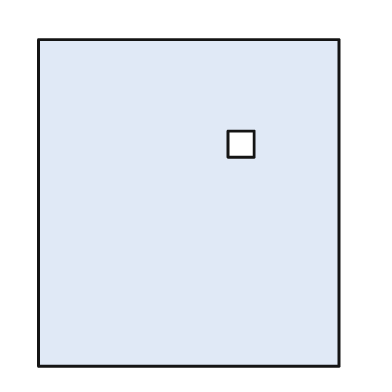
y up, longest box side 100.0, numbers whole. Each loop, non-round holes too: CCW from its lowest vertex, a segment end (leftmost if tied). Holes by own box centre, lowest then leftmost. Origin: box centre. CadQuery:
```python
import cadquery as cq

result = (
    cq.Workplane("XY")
    .moveTo(-46.0, -50.0)
    .lineTo(46.0, -50.0)
    .lineTo(46.0, 50.0)
    .lineTo(-46.0, 50.0)
    .close()
    .moveTo(12.0, 14.0)
    .lineTo(20.0, 14.0)
    .lineTo(20.0, 22.0)
    .lineTo(12.0, 22.0)
    .close()
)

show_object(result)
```